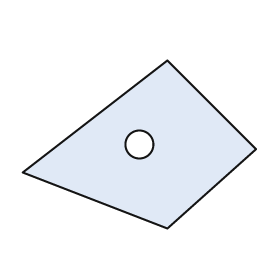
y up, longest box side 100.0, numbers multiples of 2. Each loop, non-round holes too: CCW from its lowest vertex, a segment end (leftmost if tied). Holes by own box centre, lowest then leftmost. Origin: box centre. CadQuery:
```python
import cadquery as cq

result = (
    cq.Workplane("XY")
    .moveTo(12.0, -36.0)
    .lineTo(50.0, -2.0)
    .lineTo(12.0, 36.0)
    .lineTo(-50.0, -12.0)
    .close()
    .moveTo(0.0, 0.0)
    .circle(6.0)
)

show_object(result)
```